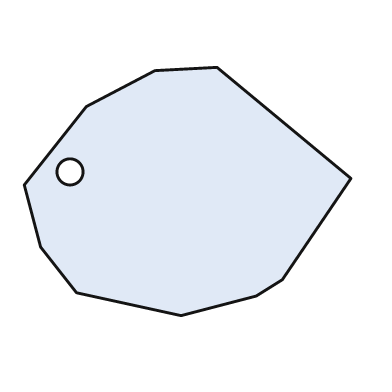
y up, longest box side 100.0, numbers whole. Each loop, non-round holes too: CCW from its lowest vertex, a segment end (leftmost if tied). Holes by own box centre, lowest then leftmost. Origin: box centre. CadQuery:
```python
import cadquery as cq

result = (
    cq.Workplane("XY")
    .moveTo(-2.0, -38.0)
    .lineTo(21.0, -32.0)
    .lineTo(29.0, -27.0)
    .lineTo(50.0, 4.0)
    .lineTo(9.0, 38.0)
    .lineTo(-10.0, 37.0)
    .lineTo(-31.0, 26.0)
    .lineTo(-50.0, 2.0)
    .lineTo(-45.0, -17.0)
    .lineTo(-34.0, -31.0)
    .close()
    .moveTo(-36.0, 6.0)
    .circle(4.0)
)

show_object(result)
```